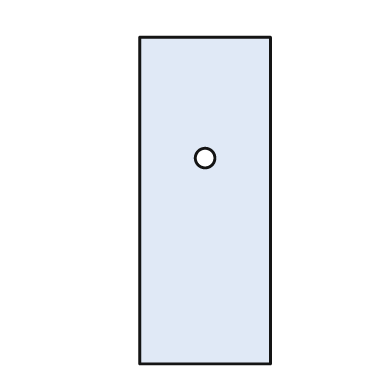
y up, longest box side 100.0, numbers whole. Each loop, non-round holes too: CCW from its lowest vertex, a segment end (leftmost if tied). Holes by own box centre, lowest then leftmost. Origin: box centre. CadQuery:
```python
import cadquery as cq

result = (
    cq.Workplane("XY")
    .moveTo(-20.0, -50.0)
    .lineTo(20.0, -50.0)
    .lineTo(20.0, 50.0)
    .lineTo(-20.0, 50.0)
    .close()
    .moveTo(0.0, 13.0)
    .circle(3.0)
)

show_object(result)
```